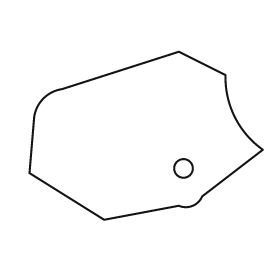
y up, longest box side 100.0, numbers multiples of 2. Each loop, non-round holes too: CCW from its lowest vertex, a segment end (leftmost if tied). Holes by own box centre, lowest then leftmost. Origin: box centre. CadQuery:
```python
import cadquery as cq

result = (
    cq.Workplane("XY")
    .moveTo(-18.0, -36.0)
    .lineTo(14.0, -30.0)
    .threePointArc((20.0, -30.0), (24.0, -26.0))
    .lineTo(50.0, -6.0)
    .threePointArc((38.0, 8.0), (34.0, 26.0))
    .lineTo(14.0, 36.0)
    .lineTo(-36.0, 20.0)
    .threePointArc((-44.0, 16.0), (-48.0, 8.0))
    .lineTo(-50.0, -16.0)
    .close()
    .moveTo(16.0, -14.0)
    .circle(4.0)
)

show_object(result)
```